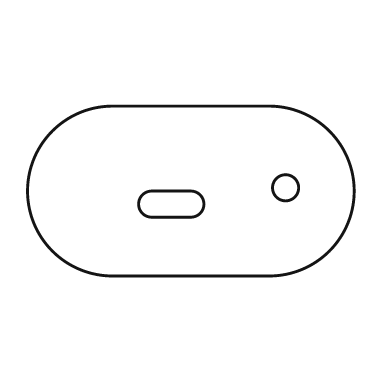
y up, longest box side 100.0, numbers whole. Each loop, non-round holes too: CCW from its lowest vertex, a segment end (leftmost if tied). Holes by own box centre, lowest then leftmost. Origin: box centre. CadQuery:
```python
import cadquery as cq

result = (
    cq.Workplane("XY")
    .moveTo(-24.0, -26.0)
    .lineTo(24.0, -26.0)
    .threePointArc((50.0, 0.0), (24.0, 26.0))
    .lineTo(-24.0, 26.0)
    .threePointArc((-50.0, 0.0), (-24.0, -26.0))
    .close()
    .moveTo(-12.0, -8.0)
    .lineTo(0.0, -8.0)
    .threePointArc((4.0, -4.0), (0.0, 0.0))
    .lineTo(-12.0, 0.0)
    .threePointArc((-16.0, -4.0), (-12.0, -8.0))
    .close()
    .moveTo(29.0, 1.0)
    .circle(4.0)
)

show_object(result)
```